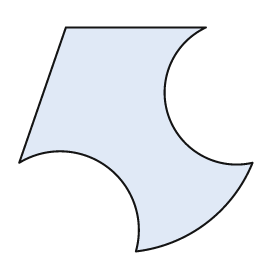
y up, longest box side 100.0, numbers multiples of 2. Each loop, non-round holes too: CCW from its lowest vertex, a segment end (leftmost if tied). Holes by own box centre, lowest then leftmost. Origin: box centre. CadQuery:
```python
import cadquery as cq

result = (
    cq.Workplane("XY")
    .moveTo(0.0, -48.0)
    .threePointArc((30.0, -36.0), (50.0, -10.0))
    .threePointArc((14.0, 10.0), (30.0, 48.0))
    .lineTo(-30.0, 48.0)
    .lineTo(-50.0, -10.0)
    .threePointArc((-12.0, -12.0), (0.0, -48.0))
    .close()
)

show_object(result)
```